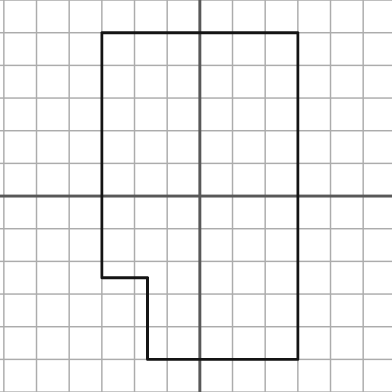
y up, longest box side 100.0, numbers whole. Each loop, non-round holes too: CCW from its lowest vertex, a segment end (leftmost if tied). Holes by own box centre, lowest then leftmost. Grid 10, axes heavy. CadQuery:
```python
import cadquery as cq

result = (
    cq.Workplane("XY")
    .moveTo(-16.0, -50.0)
    .lineTo(30.0, -50.0)
    .lineTo(30.0, 50.0)
    .lineTo(-30.0, 50.0)
    .lineTo(-30.0, -25.0)
    .lineTo(-16.0, -25.0)
    .close()
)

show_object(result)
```